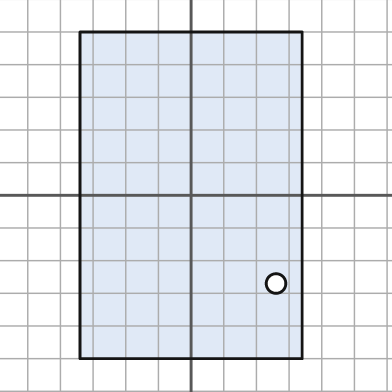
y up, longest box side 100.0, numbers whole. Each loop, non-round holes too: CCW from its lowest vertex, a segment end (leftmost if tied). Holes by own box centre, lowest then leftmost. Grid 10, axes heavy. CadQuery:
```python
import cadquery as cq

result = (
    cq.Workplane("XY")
    .moveTo(-34.0, -50.0)
    .lineTo(34.0, -50.0)
    .lineTo(34.0, 50.0)
    .lineTo(-34.0, 50.0)
    .close()
    .moveTo(26.0, -27.0)
    .circle(3.0)
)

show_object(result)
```